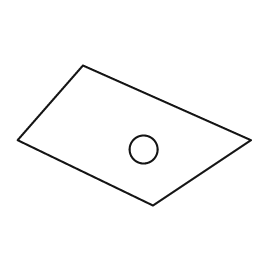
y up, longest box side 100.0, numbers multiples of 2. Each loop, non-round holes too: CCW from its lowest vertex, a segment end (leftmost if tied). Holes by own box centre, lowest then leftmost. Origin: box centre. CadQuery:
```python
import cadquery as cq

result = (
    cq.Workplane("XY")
    .moveTo(8.0, -30.0)
    .lineTo(50.0, -2.0)
    .lineTo(-22.0, 30.0)
    .lineTo(-50.0, -2.0)
    .close()
    .moveTo(4.0, -6.0)
    .circle(6.0)
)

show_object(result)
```